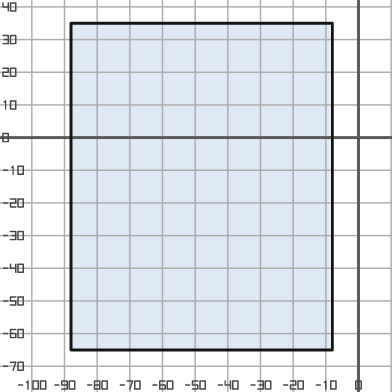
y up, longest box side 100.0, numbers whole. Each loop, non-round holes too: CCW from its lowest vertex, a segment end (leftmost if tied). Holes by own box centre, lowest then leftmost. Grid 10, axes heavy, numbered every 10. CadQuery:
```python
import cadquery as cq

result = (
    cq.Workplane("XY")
    .moveTo(-88.0, -65.0)
    .lineTo(-8.0, -65.0)
    .lineTo(-8.0, 35.0)
    .lineTo(-88.0, 35.0)
    .close()
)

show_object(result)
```